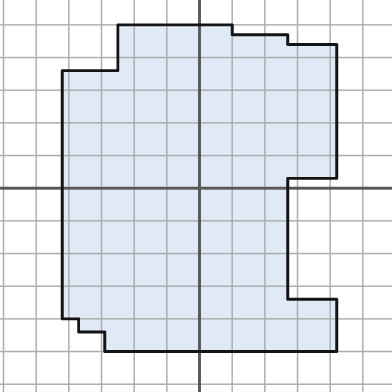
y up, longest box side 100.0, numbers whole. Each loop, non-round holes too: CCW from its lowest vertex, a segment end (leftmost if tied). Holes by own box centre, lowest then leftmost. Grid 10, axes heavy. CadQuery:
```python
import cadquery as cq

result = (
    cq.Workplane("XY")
    .moveTo(-29.0, -50.0)
    .lineTo(42.0, -50.0)
    .lineTo(42.0, -34.0)
    .lineTo(27.0, -34.0)
    .lineTo(27.0, 3.0)
    .lineTo(42.0, 3.0)
    .lineTo(42.0, 44.0)
    .lineTo(27.0, 44.0)
    .lineTo(27.0, 47.0)
    .lineTo(10.0, 47.0)
    .lineTo(10.0, 50.0)
    .lineTo(-25.0, 50.0)
    .lineTo(-25.0, 36.0)
    .lineTo(-42.0, 36.0)
    .lineTo(-42.0, -40.0)
    .lineTo(-37.0, -40.0)
    .lineTo(-37.0, -44.0)
    .lineTo(-29.0, -44.0)
    .close()
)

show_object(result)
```